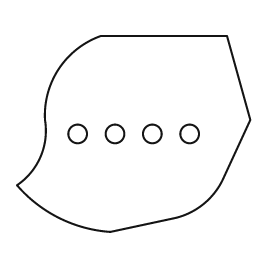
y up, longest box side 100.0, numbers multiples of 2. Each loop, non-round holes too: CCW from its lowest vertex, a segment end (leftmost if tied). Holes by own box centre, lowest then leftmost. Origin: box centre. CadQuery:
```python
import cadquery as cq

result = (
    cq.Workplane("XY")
    .moveTo(-10.0, -42.0)
    .lineTo(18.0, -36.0)
    .threePointArc((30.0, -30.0), (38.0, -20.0))
    .lineTo(50.0, 6.0)
    .lineTo(40.0, 42.0)
    .lineTo(-14.0, 42.0)
    .threePointArc((-32.0, 28.0), (-38.0, 6.0))
    .threePointArc((-40.0, -10.0), (-50.0, -22.0))
    .threePointArc((-32.0, -36.0), (-10.0, -42.0))
    .close()
    .moveTo(-24.0, 0.0)
    .circle(4.0)
    .moveTo(-8.0, 0.0)
    .circle(4.0)
    .moveTo(8.0, 0.0)
    .circle(4.0)
    .moveTo(24.0, 0.0)
    .circle(4.0)
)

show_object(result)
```